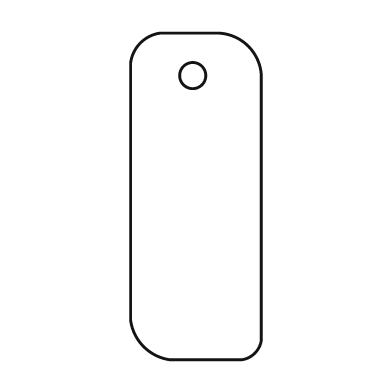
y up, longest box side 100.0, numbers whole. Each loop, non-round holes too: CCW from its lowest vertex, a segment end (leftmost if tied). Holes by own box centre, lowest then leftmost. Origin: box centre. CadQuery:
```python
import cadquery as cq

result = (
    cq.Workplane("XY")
    .moveTo(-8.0, -50.0)
    .lineTo(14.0, -50.0)
    .threePointArc((18.0, -48.0), (20.0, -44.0))
    .lineTo(20.0, 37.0)
    .threePointArc((16.0, 46.0), (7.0, 50.0))
    .lineTo(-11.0, 50.0)
    .threePointArc((-17.0, 47.0), (-20.0, 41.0))
    .lineTo(-20.0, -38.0)
    .threePointArc((-16.0, -46.0), (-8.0, -50.0))
    .close()
    .moveTo(-1.0, 37.0)
    .circle(4.0)
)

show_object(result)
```